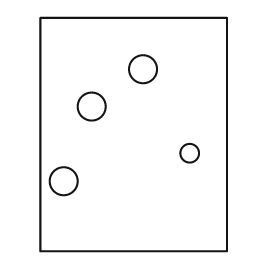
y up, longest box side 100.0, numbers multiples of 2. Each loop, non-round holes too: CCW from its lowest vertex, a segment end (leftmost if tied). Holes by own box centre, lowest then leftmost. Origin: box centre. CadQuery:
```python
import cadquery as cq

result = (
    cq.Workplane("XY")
    .moveTo(-40.0, -50.0)
    .lineTo(40.0, -50.0)
    .lineTo(40.0, 50.0)
    .lineTo(-40.0, 50.0)
    .close()
    .moveTo(-30.0, -20.0)
    .circle(6.0)
    .moveTo(24.0, -8.0)
    .circle(4.0)
    .moveTo(-18.0, 12.0)
    .circle(6.0)
    .moveTo(4.0, 28.0)
    .circle(6.0)
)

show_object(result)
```